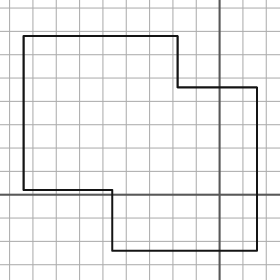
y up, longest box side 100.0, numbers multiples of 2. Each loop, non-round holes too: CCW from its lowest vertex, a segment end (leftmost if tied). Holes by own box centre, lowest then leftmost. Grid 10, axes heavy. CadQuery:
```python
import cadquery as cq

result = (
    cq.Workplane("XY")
    .moveTo(-46.0, -24.0)
    .lineTo(16.0, -24.0)
    .lineTo(16.0, 46.0)
    .lineTo(-18.0, 46.0)
    .lineTo(-18.0, 68.0)
    .lineTo(-84.0, 68.0)
    .lineTo(-84.0, 2.0)
    .lineTo(-46.0, 2.0)
    .close()
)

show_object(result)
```